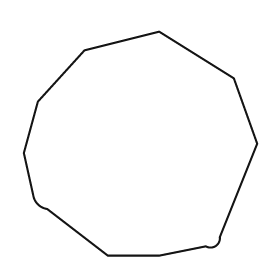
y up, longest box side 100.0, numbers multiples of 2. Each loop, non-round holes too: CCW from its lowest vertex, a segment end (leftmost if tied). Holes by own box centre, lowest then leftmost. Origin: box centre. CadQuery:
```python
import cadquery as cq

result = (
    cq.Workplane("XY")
    .moveTo(-14.0, -48.0)
    .lineTo(8.0, -48.0)
    .lineTo(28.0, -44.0)
    .threePointArc((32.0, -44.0), (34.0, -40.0))
    .lineTo(50.0, 0.0)
    .lineTo(40.0, 28.0)
    .lineTo(8.0, 48.0)
    .lineTo(-24.0, 40.0)
    .lineTo(-44.0, 18.0)
    .lineTo(-50.0, -4.0)
    .lineTo(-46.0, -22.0)
    .threePointArc((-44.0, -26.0), (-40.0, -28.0))
    .close()
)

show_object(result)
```